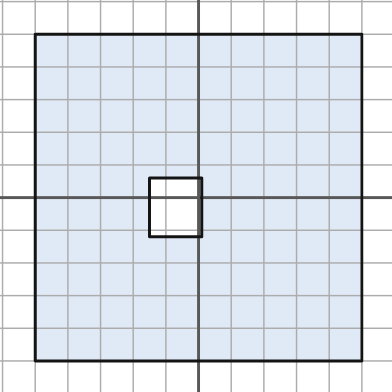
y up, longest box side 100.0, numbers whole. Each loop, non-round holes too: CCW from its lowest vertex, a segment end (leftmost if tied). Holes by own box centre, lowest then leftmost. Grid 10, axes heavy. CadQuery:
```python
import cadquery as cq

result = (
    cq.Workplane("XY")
    .moveTo(-50.0, -50.0)
    .lineTo(50.0, -50.0)
    .lineTo(50.0, 50.0)
    .lineTo(-50.0, 50.0)
    .close()
    .moveTo(-15.0, -12.0)
    .lineTo(1.0, -12.0)
    .lineTo(1.0, 6.0)
    .lineTo(-15.0, 6.0)
    .close()
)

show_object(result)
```